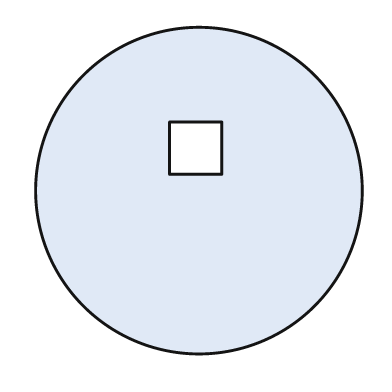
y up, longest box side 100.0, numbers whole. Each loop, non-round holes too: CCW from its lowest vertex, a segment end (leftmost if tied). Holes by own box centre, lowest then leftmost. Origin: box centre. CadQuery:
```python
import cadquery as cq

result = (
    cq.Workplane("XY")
    .moveTo(0.0, 0.0)
    .circle(50.0)
    .moveTo(-9.0, 5.0)
    .lineTo(7.0, 5.0)
    .lineTo(7.0, 21.0)
    .lineTo(-9.0, 21.0)
    .close()
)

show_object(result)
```